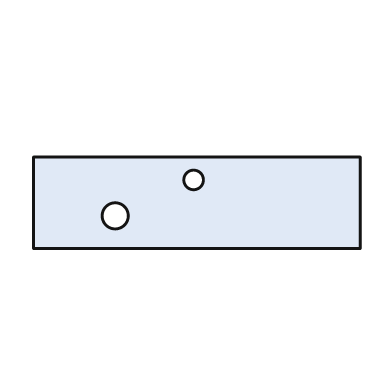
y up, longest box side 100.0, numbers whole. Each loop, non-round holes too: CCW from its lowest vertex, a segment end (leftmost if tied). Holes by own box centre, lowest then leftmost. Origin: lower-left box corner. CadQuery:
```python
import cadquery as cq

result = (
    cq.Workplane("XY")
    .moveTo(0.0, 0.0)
    .lineTo(100.0, 0.0)
    .lineTo(100.0, 28.0)
    .lineTo(0.0, 28.0)
    .close()
    .moveTo(25.0, 10.0)
    .circle(4.0)
    .moveTo(49.0, 21.0)
    .circle(3.0)
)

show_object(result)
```